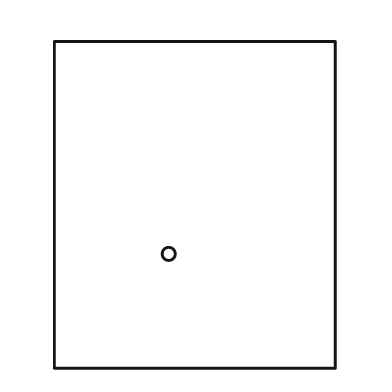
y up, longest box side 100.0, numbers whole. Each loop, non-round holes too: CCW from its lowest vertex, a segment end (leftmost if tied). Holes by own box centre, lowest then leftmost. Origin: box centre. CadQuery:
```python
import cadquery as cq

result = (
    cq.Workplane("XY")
    .moveTo(-43.0, -50.0)
    .lineTo(43.0, -50.0)
    .lineTo(43.0, 50.0)
    .lineTo(-43.0, 50.0)
    .close()
    .moveTo(-8.0, -15.0)
    .circle(2.0)
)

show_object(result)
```